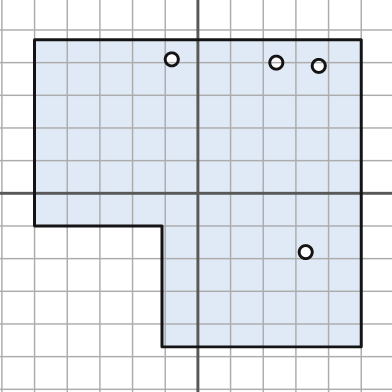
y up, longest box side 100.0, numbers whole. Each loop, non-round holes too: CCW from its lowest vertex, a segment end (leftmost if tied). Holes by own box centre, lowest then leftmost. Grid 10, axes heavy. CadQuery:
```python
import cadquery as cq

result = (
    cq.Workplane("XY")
    .moveTo(-11.0, -47.0)
    .lineTo(50.0, -47.0)
    .lineTo(50.0, 47.0)
    .lineTo(-50.0, 47.0)
    .lineTo(-50.0, -10.0)
    .lineTo(-11.0, -10.0)
    .close()
    .moveTo(33.0, -18.0)
    .circle(2.0)
    .moveTo(37.0, 39.0)
    .circle(2.0)
    .moveTo(24.0, 40.0)
    .circle(2.0)
    .moveTo(-8.0, 41.0)
    .circle(2.0)
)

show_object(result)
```